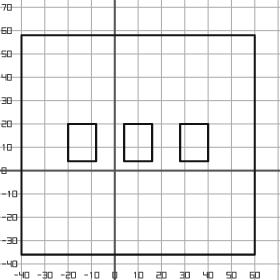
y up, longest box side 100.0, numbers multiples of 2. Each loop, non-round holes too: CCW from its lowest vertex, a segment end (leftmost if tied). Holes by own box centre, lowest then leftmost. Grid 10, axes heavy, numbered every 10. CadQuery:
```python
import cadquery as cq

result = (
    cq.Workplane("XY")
    .moveTo(-40.0, -36.0)
    .lineTo(60.0, -36.0)
    .lineTo(60.0, 58.0)
    .lineTo(-40.0, 58.0)
    .close()
    .moveTo(-20.0, 4.0)
    .lineTo(-8.0, 4.0)
    .lineTo(-8.0, 20.0)
    .lineTo(-20.0, 20.0)
    .close()
    .moveTo(4.0, 4.0)
    .lineTo(16.0, 4.0)
    .lineTo(16.0, 20.0)
    .lineTo(4.0, 20.0)
    .close()
    .moveTo(28.0, 4.0)
    .lineTo(40.0, 4.0)
    .lineTo(40.0, 20.0)
    .lineTo(28.0, 20.0)
    .close()
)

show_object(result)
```